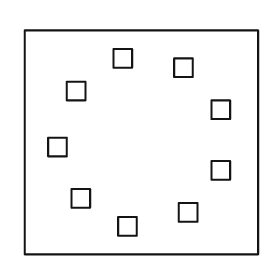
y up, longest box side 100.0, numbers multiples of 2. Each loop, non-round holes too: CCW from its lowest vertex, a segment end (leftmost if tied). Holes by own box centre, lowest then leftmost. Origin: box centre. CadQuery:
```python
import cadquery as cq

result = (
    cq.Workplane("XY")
    .moveTo(-50.0, -48.0)
    .lineTo(50.0, -48.0)
    .lineTo(50.0, 48.0)
    .lineTo(-50.0, 48.0)
    .close()
    .moveTo(-10.0, -40.0)
    .lineTo(-2.0, -40.0)
    .lineTo(-2.0, -32.0)
    .lineTo(-10.0, -32.0)
    .close()
    .moveTo(16.0, -34.0)
    .lineTo(24.0, -34.0)
    .lineTo(24.0, -26.0)
    .lineTo(16.0, -26.0)
    .close()
    .moveTo(-30.0, -28.0)
    .lineTo(-22.0, -28.0)
    .lineTo(-22.0, -20.0)
    .lineTo(-30.0, -20.0)
    .close()
    .moveTo(30.0, -16.0)
    .lineTo(38.0, -16.0)
    .lineTo(38.0, -8.0)
    .lineTo(30.0, -8.0)
    .close()
    .moveTo(-40.0, -6.0)
    .lineTo(-32.0, -6.0)
    .lineTo(-32.0, 2.0)
    .lineTo(-40.0, 2.0)
    .close()
    .moveTo(30.0, 10.0)
    .lineTo(38.0, 10.0)
    .lineTo(38.0, 18.0)
    .lineTo(30.0, 18.0)
    .close()
    .moveTo(-32.0, 18.0)
    .lineTo(-24.0, 18.0)
    .lineTo(-24.0, 26.0)
    .lineTo(-32.0, 26.0)
    .close()
    .moveTo(14.0, 28.0)
    .lineTo(22.0, 28.0)
    .lineTo(22.0, 36.0)
    .lineTo(14.0, 36.0)
    .close()
    .moveTo(-12.0, 32.0)
    .lineTo(-4.0, 32.0)
    .lineTo(-4.0, 40.0)
    .lineTo(-12.0, 40.0)
    .close()
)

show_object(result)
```